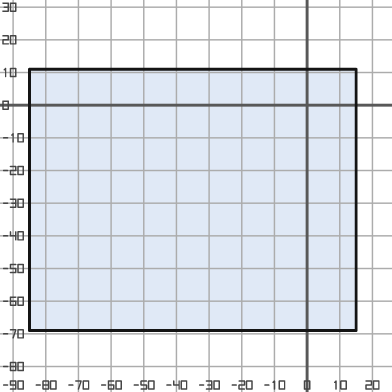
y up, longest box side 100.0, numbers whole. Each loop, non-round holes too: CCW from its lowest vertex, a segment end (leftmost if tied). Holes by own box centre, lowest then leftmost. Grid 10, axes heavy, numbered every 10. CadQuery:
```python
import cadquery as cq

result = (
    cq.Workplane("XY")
    .moveTo(-85.0, -69.0)
    .lineTo(15.0, -69.0)
    .lineTo(15.0, 11.0)
    .lineTo(-85.0, 11.0)
    .close()
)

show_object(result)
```